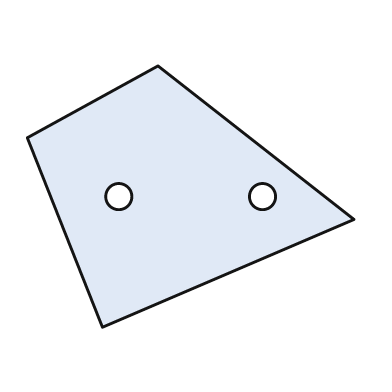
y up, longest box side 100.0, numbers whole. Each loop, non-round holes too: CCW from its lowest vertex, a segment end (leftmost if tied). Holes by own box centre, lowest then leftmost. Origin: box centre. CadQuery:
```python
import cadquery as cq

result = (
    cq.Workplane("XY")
    .moveTo(-27.0, -40.0)
    .lineTo(50.0, -7.0)
    .lineTo(-10.0, 40.0)
    .lineTo(-50.0, 18.0)
    .close()
    .moveTo(-22.0, 0.0)
    .circle(4.0)
    .moveTo(22.0, 0.0)
    .circle(4.0)
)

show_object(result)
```